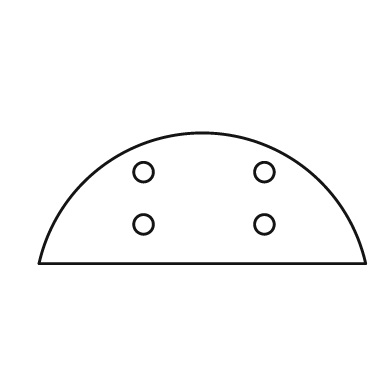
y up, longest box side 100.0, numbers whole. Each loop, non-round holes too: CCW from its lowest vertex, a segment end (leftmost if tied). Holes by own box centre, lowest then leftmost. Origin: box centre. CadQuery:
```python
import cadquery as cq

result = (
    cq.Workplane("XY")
    .moveTo(-50.0, -20.0)
    .lineTo(50.0, -20.0)
    .threePointArc((0.0, 20.0), (-50.0, -20.0))
    .close()
    .moveTo(-18.0, -8.0)
    .circle(3.0)
    .moveTo(19.0, -8.0)
    .circle(3.0)
    .moveTo(-18.0, 8.0)
    .circle(3.0)
    .moveTo(19.0, 8.0)
    .circle(3.0)
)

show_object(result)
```